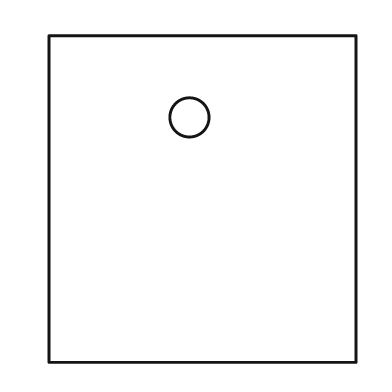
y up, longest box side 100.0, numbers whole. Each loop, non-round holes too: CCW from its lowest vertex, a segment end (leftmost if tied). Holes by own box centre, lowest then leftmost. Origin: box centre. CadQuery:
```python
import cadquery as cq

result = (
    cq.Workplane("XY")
    .moveTo(-47.0, -50.0)
    .lineTo(47.0, -50.0)
    .lineTo(47.0, 50.0)
    .lineTo(-47.0, 50.0)
    .close()
    .moveTo(-4.0, 25.0)
    .circle(6.0)
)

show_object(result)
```